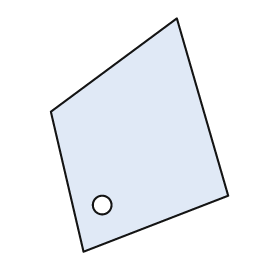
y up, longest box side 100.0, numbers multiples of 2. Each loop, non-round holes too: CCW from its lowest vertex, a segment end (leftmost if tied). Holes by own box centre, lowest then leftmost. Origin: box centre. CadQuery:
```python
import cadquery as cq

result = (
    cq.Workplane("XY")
    .moveTo(-24.0, -50.0)
    .lineTo(38.0, -26.0)
    .lineTo(16.0, 50.0)
    .lineTo(-38.0, 10.0)
    .close()
    .moveTo(-16.0, -30.0)
    .circle(4.0)
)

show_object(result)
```